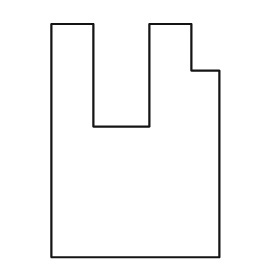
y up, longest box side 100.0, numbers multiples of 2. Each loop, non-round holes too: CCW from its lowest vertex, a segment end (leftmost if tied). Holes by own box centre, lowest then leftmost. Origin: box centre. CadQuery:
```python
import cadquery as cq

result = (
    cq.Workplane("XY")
    .moveTo(-36.0, -50.0)
    .lineTo(36.0, -50.0)
    .lineTo(36.0, 30.0)
    .lineTo(24.0, 30.0)
    .lineTo(24.0, 50.0)
    .lineTo(6.0, 50.0)
    .lineTo(6.0, 6.0)
    .lineTo(-18.0, 6.0)
    .lineTo(-18.0, 50.0)
    .lineTo(-36.0, 50.0)
    .close()
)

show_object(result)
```